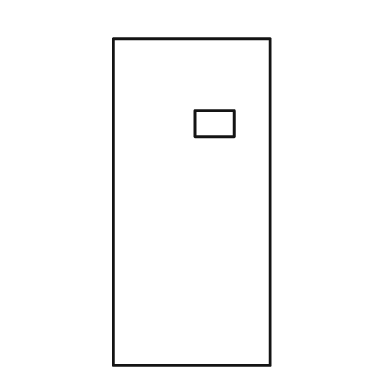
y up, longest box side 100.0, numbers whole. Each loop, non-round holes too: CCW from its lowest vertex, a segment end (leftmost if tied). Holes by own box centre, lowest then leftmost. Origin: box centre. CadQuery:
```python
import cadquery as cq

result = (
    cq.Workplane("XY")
    .moveTo(-24.0, -50.0)
    .lineTo(24.0, -50.0)
    .lineTo(24.0, 50.0)
    .lineTo(-24.0, 50.0)
    .close()
    .moveTo(1.0, 20.0)
    .lineTo(13.0, 20.0)
    .lineTo(13.0, 28.0)
    .lineTo(1.0, 28.0)
    .close()
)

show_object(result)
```